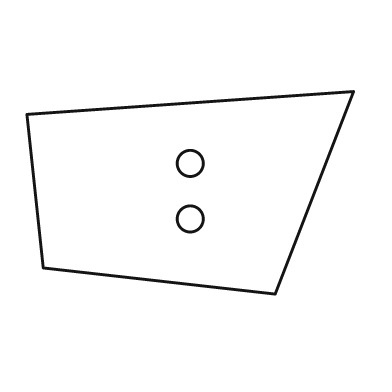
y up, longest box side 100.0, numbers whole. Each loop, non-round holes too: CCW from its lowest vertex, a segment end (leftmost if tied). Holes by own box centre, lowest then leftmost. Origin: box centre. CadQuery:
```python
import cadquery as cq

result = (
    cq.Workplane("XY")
    .moveTo(26.0, -31.0)
    .lineTo(50.0, 31.0)
    .lineTo(-50.0, 24.0)
    .lineTo(-45.0, -23.0)
    .close()
    .moveTo(0.0, -8.0)
    .circle(4.0)
    .moveTo(0.0, 9.0)
    .circle(4.0)
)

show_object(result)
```